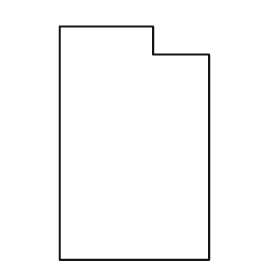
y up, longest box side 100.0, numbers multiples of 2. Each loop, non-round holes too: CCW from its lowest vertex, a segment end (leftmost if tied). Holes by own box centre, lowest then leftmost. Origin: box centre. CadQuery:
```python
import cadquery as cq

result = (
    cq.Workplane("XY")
    .moveTo(-32.0, -50.0)
    .lineTo(32.0, -50.0)
    .lineTo(32.0, 38.0)
    .lineTo(8.0, 38.0)
    .lineTo(8.0, 50.0)
    .lineTo(-32.0, 50.0)
    .close()
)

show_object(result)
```